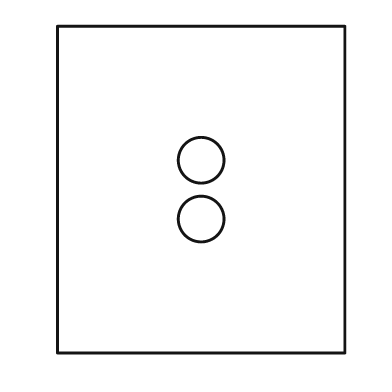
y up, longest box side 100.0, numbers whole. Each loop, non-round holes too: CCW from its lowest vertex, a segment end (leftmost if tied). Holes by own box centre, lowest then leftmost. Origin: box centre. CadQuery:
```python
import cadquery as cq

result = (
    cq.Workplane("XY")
    .moveTo(-44.0, -50.0)
    .lineTo(44.0, -50.0)
    .lineTo(44.0, 50.0)
    .lineTo(-44.0, 50.0)
    .close()
    .moveTo(0.0, -9.0)
    .circle(7.0)
    .moveTo(0.0, 9.0)
    .circle(7.0)
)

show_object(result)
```